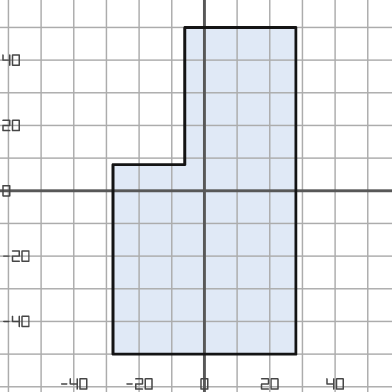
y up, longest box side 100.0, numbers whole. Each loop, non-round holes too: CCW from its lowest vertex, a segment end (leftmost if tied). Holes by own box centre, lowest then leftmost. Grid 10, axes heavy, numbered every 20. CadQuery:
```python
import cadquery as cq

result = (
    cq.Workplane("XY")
    .moveTo(-28.0, -50.0)
    .lineTo(28.0, -50.0)
    .lineTo(28.0, 50.0)
    .lineTo(-6.0, 50.0)
    .lineTo(-6.0, 8.0)
    .lineTo(-28.0, 8.0)
    .close()
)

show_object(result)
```